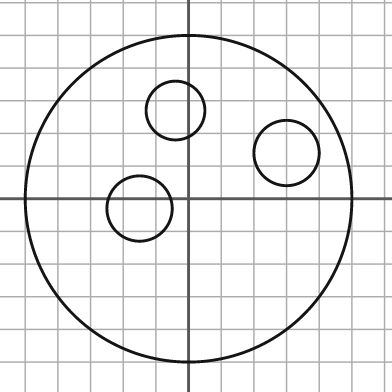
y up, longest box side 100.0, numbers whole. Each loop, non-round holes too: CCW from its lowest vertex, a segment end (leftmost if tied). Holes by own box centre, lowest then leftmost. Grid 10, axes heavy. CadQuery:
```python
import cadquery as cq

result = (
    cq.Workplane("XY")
    .moveTo(0.0, 0.0)
    .circle(50.0)
    .moveTo(-15.0, -3.0)
    .circle(10.0)
    .moveTo(30.0, 14.0)
    .circle(10.0)
    .moveTo(-4.0, 27.0)
    .circle(9.0)
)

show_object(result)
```